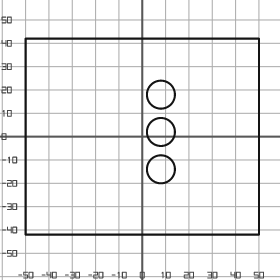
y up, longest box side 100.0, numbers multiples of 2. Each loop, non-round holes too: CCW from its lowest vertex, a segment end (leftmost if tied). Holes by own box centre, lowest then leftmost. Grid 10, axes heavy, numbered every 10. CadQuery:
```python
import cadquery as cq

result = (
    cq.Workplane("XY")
    .moveTo(-50.0, -42.0)
    .lineTo(50.0, -42.0)
    .lineTo(50.0, 42.0)
    .lineTo(-50.0, 42.0)
    .close()
    .moveTo(8.0, -14.0)
    .circle(6.0)
    .moveTo(8.0, 2.0)
    .circle(6.0)
    .moveTo(8.0, 18.0)
    .circle(6.0)
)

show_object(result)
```